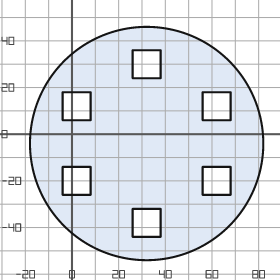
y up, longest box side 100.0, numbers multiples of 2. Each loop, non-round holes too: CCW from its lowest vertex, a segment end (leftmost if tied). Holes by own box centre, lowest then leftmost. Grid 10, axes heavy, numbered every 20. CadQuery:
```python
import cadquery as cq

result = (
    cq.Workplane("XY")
    .moveTo(32.0, -4.0)
    .circle(50.0)
    .moveTo(26.0, -44.0)
    .lineTo(38.0, -44.0)
    .lineTo(38.0, -32.0)
    .lineTo(26.0, -32.0)
    .close()
    .moveTo(-4.0, -26.0)
    .lineTo(8.0, -26.0)
    .lineTo(8.0, -14.0)
    .lineTo(-4.0, -14.0)
    .close()
    .moveTo(56.0, -26.0)
    .lineTo(68.0, -26.0)
    .lineTo(68.0, -14.0)
    .lineTo(56.0, -14.0)
    .close()
    .moveTo(-4.0, 6.0)
    .lineTo(8.0, 6.0)
    .lineTo(8.0, 18.0)
    .lineTo(-4.0, 18.0)
    .close()
    .moveTo(56.0, 6.0)
    .lineTo(68.0, 6.0)
    .lineTo(68.0, 18.0)
    .lineTo(56.0, 18.0)
    .close()
    .moveTo(26.0, 24.0)
    .lineTo(38.0, 24.0)
    .lineTo(38.0, 36.0)
    .lineTo(26.0, 36.0)
    .close()
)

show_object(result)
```